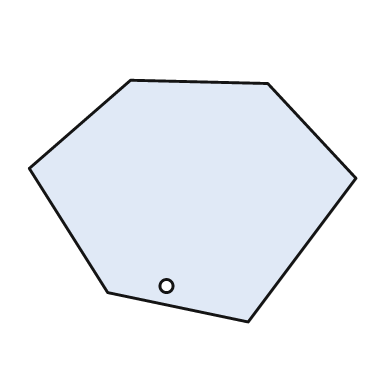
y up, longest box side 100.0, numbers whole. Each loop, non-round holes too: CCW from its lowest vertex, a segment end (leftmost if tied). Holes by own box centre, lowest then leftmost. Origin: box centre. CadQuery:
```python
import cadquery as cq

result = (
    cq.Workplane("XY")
    .moveTo(17.0, -37.0)
    .lineTo(50.0, 7.0)
    .lineTo(23.0, 36.0)
    .lineTo(-19.0, 37.0)
    .lineTo(-50.0, 10.0)
    .lineTo(-26.0, -28.0)
    .close()
    .moveTo(-8.0, -26.0)
    .circle(2.0)
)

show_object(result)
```